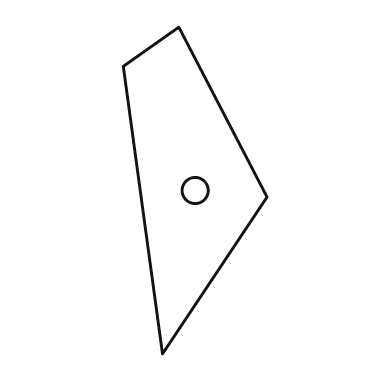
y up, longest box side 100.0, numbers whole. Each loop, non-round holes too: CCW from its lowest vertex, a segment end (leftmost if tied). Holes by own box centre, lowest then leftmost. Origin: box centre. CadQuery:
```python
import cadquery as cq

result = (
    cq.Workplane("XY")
    .moveTo(-10.0, -50.0)
    .lineTo(22.0, -2.0)
    .lineTo(-5.0, 50.0)
    .lineTo(-22.0, 38.0)
    .close()
    .moveTo(0.0, 0.0)
    .circle(4.0)
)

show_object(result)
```